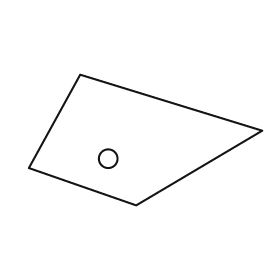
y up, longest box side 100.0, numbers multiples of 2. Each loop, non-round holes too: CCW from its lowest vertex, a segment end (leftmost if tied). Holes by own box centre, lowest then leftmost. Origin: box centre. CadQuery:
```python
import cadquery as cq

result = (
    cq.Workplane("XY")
    .moveTo(-4.0, -28.0)
    .lineTo(50.0, 4.0)
    .lineTo(-28.0, 28.0)
    .lineTo(-50.0, -12.0)
    .close()
    .moveTo(-16.0, -8.0)
    .circle(4.0)
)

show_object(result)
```